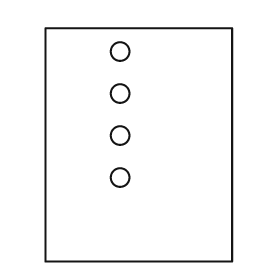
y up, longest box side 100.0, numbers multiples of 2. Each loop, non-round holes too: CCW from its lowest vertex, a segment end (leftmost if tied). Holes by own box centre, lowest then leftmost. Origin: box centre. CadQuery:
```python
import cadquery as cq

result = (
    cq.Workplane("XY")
    .moveTo(-40.0, -50.0)
    .lineTo(40.0, -50.0)
    .lineTo(40.0, 50.0)
    .lineTo(-40.0, 50.0)
    .close()
    .moveTo(-8.0, -14.0)
    .circle(4.0)
    .moveTo(-8.0, 4.0)
    .circle(4.0)
    .moveTo(-8.0, 22.0)
    .circle(4.0)
    .moveTo(-8.0, 40.0)
    .circle(4.0)
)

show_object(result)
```